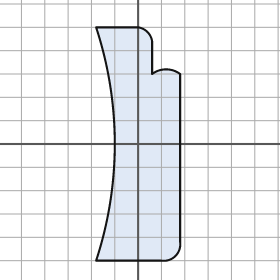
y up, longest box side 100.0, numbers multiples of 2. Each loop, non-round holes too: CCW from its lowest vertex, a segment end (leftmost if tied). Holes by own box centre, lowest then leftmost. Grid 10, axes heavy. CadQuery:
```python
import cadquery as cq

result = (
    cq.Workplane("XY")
    .moveTo(-18.0, -50.0)
    .lineTo(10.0, -50.0)
    .threePointArc((16.0, -48.0), (18.0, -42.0))
    .lineTo(18.0, 30.0)
    .threePointArc((12.0, 32.0), (6.0, 30.0))
    .lineTo(6.0, 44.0)
    .threePointArc((4.0, 48.0), (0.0, 50.0))
    .lineTo(-18.0, 50.0)
    .threePointArc((-10.0, 0.0), (-18.0, -50.0))
    .close()
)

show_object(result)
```